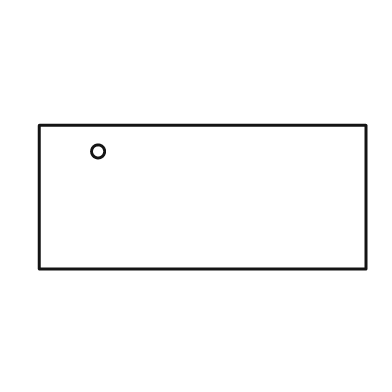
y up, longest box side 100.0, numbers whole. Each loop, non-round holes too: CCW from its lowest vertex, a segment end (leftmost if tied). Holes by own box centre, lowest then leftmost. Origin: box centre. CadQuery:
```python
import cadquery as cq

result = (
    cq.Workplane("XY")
    .moveTo(-50.0, -22.0)
    .lineTo(50.0, -22.0)
    .lineTo(50.0, 22.0)
    .lineTo(-50.0, 22.0)
    .close()
    .moveTo(-32.0, 14.0)
    .circle(2.0)
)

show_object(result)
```